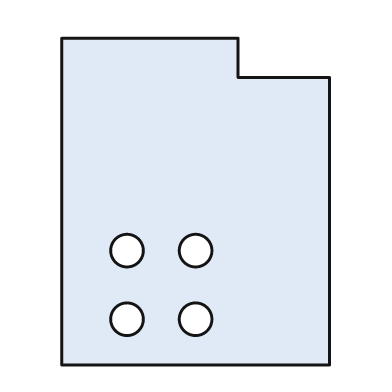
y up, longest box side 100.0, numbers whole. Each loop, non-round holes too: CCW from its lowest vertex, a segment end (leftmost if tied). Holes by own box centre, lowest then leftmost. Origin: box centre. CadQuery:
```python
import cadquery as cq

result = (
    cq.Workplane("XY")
    .moveTo(-41.0, -50.0)
    .lineTo(41.0, -50.0)
    .lineTo(41.0, 38.0)
    .lineTo(13.0, 38.0)
    .lineTo(13.0, 50.0)
    .lineTo(-41.0, 50.0)
    .close()
    .moveTo(-21.0, -36.0)
    .circle(5.0)
    .moveTo(0.0, -36.0)
    .circle(5.0)
    .moveTo(-21.0, -15.0)
    .circle(5.0)
    .moveTo(0.0, -15.0)
    .circle(5.0)
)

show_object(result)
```